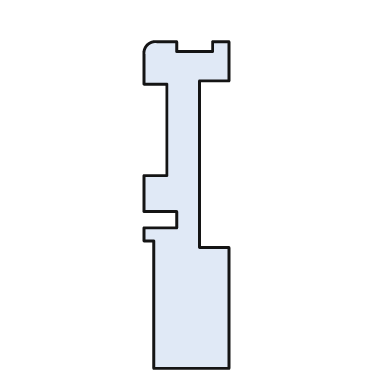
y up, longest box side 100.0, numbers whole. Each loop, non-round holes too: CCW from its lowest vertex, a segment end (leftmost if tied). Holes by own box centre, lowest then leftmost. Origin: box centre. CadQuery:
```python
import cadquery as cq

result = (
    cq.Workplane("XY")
    .moveTo(-10.0, -50.0)
    .lineTo(13.0, -50.0)
    .lineTo(13.0, -13.0)
    .lineTo(4.0, -13.0)
    .lineTo(4.0, 38.0)
    .lineTo(13.0, 38.0)
    .lineTo(13.0, 50.0)
    .lineTo(8.0, 50.0)
    .lineTo(8.0, 47.0)
    .lineTo(-3.0, 47.0)
    .lineTo(-3.0, 50.0)
    .lineTo(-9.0, 50.0)
    .threePointArc((-12.0, 49.0), (-13.0, 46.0))
    .lineTo(-13.0, 37.0)
    .lineTo(-6.0, 37.0)
    .lineTo(-6.0, 9.0)
    .lineTo(-13.0, 9.0)
    .lineTo(-13.0, -2.0)
    .lineTo(-3.0, -2.0)
    .lineTo(-3.0, -7.0)
    .lineTo(-13.0, -7.0)
    .lineTo(-13.0, -11.0)
    .lineTo(-10.0, -11.0)
    .close()
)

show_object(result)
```